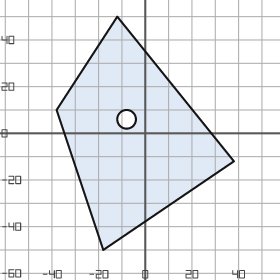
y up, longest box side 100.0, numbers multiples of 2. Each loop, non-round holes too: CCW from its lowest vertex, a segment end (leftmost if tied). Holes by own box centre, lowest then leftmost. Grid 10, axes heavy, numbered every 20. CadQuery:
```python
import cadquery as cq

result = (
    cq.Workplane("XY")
    .moveTo(-18.0, -50.0)
    .lineTo(38.0, -12.0)
    .lineTo(-12.0, 50.0)
    .lineTo(-38.0, 10.0)
    .close()
    .moveTo(-8.0, 6.0)
    .circle(4.0)
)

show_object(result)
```